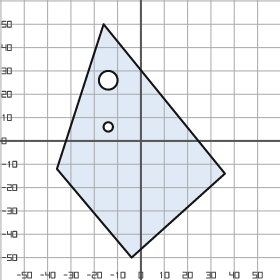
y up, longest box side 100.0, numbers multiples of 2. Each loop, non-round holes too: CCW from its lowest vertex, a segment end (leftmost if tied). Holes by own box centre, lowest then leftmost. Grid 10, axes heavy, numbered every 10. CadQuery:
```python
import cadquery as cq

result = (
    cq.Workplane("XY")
    .moveTo(-4.0, -50.0)
    .lineTo(36.0, -14.0)
    .lineTo(-16.0, 50.0)
    .lineTo(-36.0, -12.0)
    .close()
    .moveTo(-14.0, 6.0)
    .circle(2.0)
    .moveTo(-14.0, 26.0)
    .circle(4.0)
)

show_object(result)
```